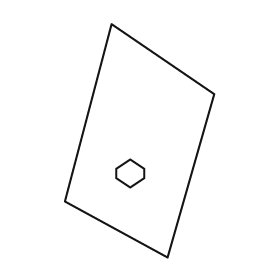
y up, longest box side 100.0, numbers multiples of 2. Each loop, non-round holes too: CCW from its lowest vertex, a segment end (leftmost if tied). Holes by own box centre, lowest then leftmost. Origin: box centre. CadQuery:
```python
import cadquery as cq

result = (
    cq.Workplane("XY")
    .moveTo(12.0, -50.0)
    .lineTo(32.0, 20.0)
    .lineTo(-12.0, 50.0)
    .lineTo(-32.0, -26.0)
    .close()
    .moveTo(-4.0, -20.0)
    .lineTo(2.0, -16.0)
    .lineTo(2.0, -12.0)
    .lineTo(-4.0, -8.0)
    .lineTo(-10.0, -12.0)
    .lineTo(-10.0, -16.0)
    .close()
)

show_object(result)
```